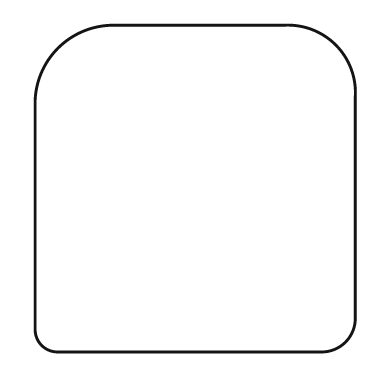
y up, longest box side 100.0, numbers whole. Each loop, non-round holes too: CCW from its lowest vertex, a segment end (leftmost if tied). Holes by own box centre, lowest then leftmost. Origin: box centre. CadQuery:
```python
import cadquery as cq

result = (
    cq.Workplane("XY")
    .moveTo(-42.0, -50.0)
    .lineTo(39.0, -50.0)
    .threePointArc((46.0, -47.0), (49.0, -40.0))
    .lineTo(49.0, 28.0)
    .threePointArc((43.0, 44.0), (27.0, 50.0))
    .lineTo(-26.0, 50.0)
    .threePointArc((-42.0, 43.0), (-49.0, 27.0))
    .lineTo(-49.0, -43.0)
    .threePointArc((-47.0, -48.0), (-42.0, -50.0))
    .close()
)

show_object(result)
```